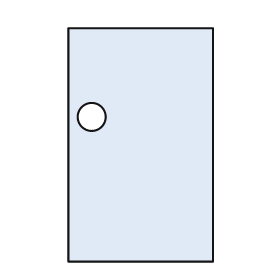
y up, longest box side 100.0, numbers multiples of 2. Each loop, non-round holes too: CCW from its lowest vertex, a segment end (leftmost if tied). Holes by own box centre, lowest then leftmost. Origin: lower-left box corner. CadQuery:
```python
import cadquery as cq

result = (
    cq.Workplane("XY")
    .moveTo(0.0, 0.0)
    .lineTo(62.0, 0.0)
    .lineTo(62.0, 100.0)
    .lineTo(0.0, 100.0)
    .close()
    .moveTo(10.0, 62.0)
    .circle(6.0)
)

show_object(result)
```